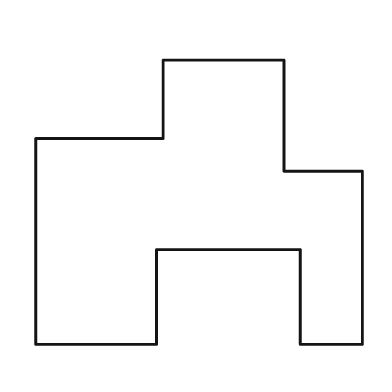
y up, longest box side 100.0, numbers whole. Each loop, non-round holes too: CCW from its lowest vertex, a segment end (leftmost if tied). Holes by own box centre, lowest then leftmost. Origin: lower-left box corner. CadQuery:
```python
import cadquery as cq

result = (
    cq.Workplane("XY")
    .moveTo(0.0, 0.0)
    .lineTo(37.0, 0.0)
    .lineTo(37.0, 29.0)
    .lineTo(81.0, 29.0)
    .lineTo(81.0, 0.0)
    .lineTo(100.0, 0.0)
    .lineTo(100.0, 53.0)
    .lineTo(76.0, 53.0)
    .lineTo(76.0, 87.0)
    .lineTo(39.0, 87.0)
    .lineTo(39.0, 63.0)
    .lineTo(0.0, 63.0)
    .close()
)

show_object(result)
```